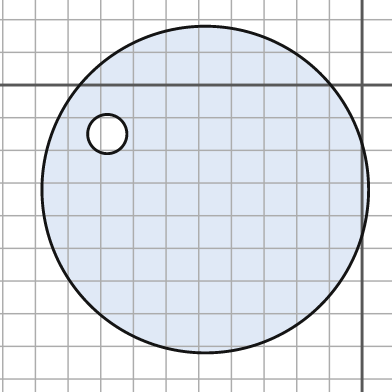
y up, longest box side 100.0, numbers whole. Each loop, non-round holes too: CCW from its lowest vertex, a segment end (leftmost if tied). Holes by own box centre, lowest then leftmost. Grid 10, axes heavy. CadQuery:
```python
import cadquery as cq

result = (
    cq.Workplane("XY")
    .moveTo(-48.0, -32.0)
    .circle(50.0)
    .moveTo(-78.0, -15.0)
    .circle(6.0)
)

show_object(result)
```